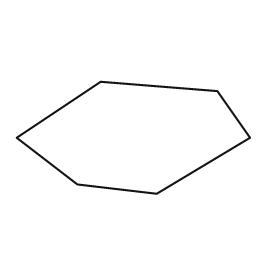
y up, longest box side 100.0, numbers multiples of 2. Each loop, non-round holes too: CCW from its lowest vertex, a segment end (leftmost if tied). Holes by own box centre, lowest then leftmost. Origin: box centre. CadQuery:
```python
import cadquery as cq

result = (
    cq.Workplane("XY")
    .moveTo(10.0, -24.0)
    .lineTo(50.0, 0.0)
    .lineTo(36.0, 20.0)
    .lineTo(-14.0, 24.0)
    .lineTo(-50.0, 0.0)
    .lineTo(-24.0, -20.0)
    .close()
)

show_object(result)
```